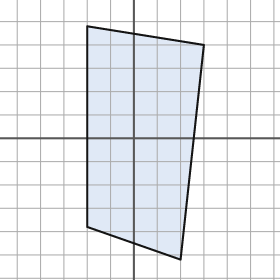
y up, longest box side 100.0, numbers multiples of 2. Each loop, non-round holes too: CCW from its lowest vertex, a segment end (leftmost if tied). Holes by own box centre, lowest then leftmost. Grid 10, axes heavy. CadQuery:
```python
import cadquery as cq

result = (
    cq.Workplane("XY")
    .moveTo(20.0, -52.0)
    .lineTo(30.0, 40.0)
    .lineTo(-20.0, 48.0)
    .lineTo(-20.0, -38.0)
    .close()
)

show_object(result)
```